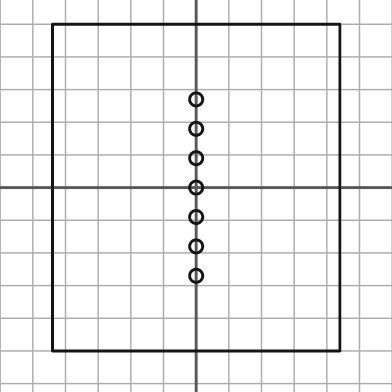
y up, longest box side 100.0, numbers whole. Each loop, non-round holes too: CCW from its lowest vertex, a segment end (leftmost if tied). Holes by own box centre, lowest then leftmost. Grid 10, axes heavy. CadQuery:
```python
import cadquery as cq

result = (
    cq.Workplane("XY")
    .moveTo(-44.0, -50.0)
    .lineTo(44.0, -50.0)
    .lineTo(44.0, 50.0)
    .lineTo(-44.0, 50.0)
    .close()
    .moveTo(0.0, -27.0)
    .circle(2.0)
    .moveTo(0.0, -18.0)
    .circle(2.0)
    .moveTo(0.0, -9.0)
    .circle(2.0)
    .moveTo(0.0, 0.0)
    .circle(2.0)
    .moveTo(0.0, 9.0)
    .circle(2.0)
    .moveTo(0.0, 18.0)
    .circle(2.0)
    .moveTo(0.0, 27.0)
    .circle(2.0)
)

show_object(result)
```